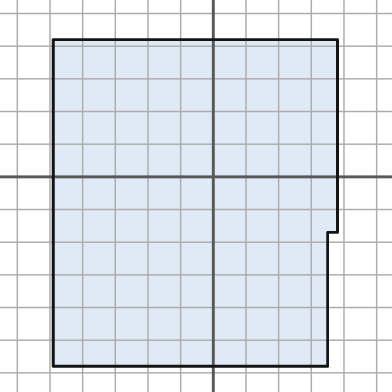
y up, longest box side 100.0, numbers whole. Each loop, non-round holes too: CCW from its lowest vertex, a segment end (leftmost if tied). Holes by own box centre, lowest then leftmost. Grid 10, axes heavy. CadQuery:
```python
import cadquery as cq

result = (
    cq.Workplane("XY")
    .moveTo(-49.0, -58.0)
    .lineTo(35.0, -58.0)
    .lineTo(35.0, -17.0)
    .lineTo(38.0, -17.0)
    .lineTo(38.0, 42.0)
    .lineTo(-49.0, 42.0)
    .close()
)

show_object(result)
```